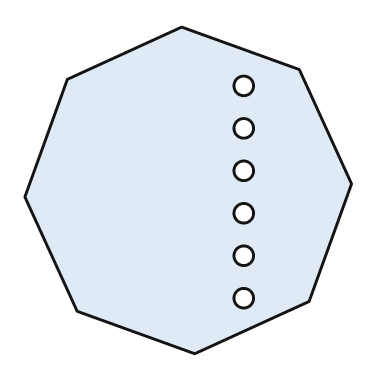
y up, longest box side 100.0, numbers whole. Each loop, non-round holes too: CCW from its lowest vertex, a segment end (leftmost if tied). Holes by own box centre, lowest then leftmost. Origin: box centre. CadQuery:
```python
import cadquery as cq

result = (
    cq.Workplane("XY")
    .moveTo(2.0, -50.0)
    .lineTo(37.0, -34.0)
    .lineTo(50.0, 2.0)
    .lineTo(34.0, 37.0)
    .lineTo(-2.0, 50.0)
    .lineTo(-37.0, 34.0)
    .lineTo(-50.0, -2.0)
    .lineTo(-34.0, -37.0)
    .close()
    .moveTo(17.0, -33.0)
    .circle(3.0)
    .moveTo(17.0, -20.0)
    .circle(3.0)
    .moveTo(17.0, -7.0)
    .circle(3.0)
    .moveTo(17.0, 6.0)
    .circle(3.0)
    .moveTo(17.0, 19.0)
    .circle(3.0)
    .moveTo(17.0, 32.0)
    .circle(3.0)
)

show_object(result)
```